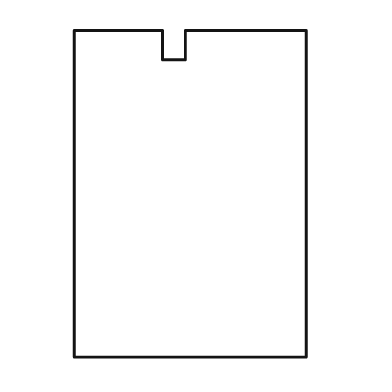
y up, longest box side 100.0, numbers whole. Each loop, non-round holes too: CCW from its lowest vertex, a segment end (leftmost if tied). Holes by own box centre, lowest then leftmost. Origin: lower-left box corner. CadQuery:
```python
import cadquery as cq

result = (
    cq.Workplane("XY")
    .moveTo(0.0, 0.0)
    .lineTo(71.0, 0.0)
    .lineTo(71.0, 100.0)
    .lineTo(34.0, 100.0)
    .lineTo(34.0, 91.0)
    .lineTo(27.0, 91.0)
    .lineTo(27.0, 100.0)
    .lineTo(0.0, 100.0)
    .close()
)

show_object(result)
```